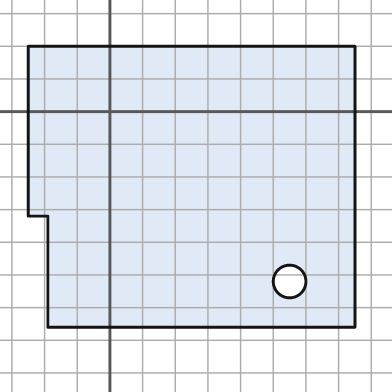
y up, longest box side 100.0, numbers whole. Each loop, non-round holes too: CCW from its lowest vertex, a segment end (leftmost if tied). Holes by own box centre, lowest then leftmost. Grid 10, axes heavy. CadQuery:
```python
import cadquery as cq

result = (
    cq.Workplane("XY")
    .moveTo(-19.0, -66.0)
    .lineTo(75.0, -66.0)
    .lineTo(75.0, 20.0)
    .lineTo(-25.0, 20.0)
    .lineTo(-25.0, -32.0)
    .lineTo(-19.0, -32.0)
    .close()
    .moveTo(55.0, -52.0)
    .circle(5.0)
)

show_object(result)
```